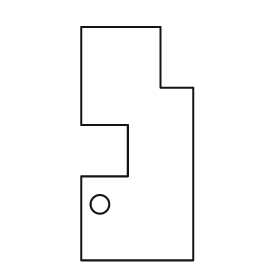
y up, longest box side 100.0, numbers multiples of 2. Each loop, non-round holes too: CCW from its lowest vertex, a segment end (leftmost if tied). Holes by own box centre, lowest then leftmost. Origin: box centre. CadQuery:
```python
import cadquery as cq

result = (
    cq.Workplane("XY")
    .moveTo(-24.0, -50.0)
    .lineTo(24.0, -50.0)
    .lineTo(24.0, 24.0)
    .lineTo(10.0, 24.0)
    .lineTo(10.0, 50.0)
    .lineTo(-24.0, 50.0)
    .lineTo(-24.0, 8.0)
    .lineTo(-4.0, 8.0)
    .lineTo(-4.0, -14.0)
    .lineTo(-24.0, -14.0)
    .close()
    .moveTo(-16.0, -26.0)
    .circle(4.0)
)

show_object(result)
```